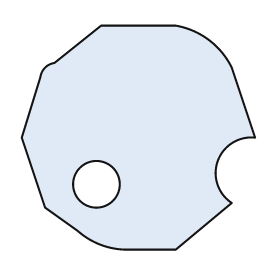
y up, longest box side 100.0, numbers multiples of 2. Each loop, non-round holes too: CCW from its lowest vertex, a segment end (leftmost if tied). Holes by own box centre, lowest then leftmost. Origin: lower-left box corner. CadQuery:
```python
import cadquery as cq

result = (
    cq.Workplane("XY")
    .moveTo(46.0, 0.0)
    .lineTo(66.0, 0.0)
    .lineTo(90.0, 20.0)
    .threePointArc((84.0, 38.0), (100.0, 48.0))
    .lineTo(90.0, 78.0)
    .threePointArc((80.0, 90.0), (66.0, 96.0))
    .lineTo(34.0, 96.0)
    .lineTo(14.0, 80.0)
    .threePointArc((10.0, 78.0), (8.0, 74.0))
    .lineTo(0.0, 48.0)
    .lineTo(10.0, 18.0)
    .lineTo(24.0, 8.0)
    .threePointArc((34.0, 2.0), (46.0, 0.0))
    .close()
    .moveTo(32.0, 28.0)
    .circle(10.0)
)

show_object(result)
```